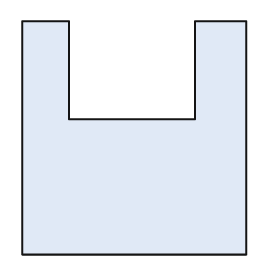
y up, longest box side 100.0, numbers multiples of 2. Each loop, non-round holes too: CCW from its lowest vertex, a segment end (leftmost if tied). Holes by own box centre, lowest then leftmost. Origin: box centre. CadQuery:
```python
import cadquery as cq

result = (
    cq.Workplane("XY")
    .moveTo(-48.0, -50.0)
    .lineTo(48.0, -50.0)
    .lineTo(48.0, 50.0)
    .lineTo(26.0, 50.0)
    .lineTo(26.0, 8.0)
    .lineTo(-28.0, 8.0)
    .lineTo(-28.0, 50.0)
    .lineTo(-48.0, 50.0)
    .close()
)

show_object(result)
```